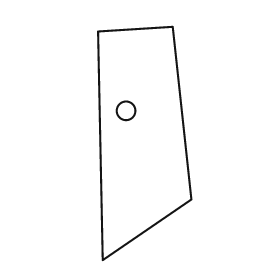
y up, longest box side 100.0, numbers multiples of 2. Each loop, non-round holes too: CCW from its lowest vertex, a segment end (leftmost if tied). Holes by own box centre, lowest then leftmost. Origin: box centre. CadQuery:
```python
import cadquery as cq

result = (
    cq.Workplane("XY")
    .moveTo(-18.0, -50.0)
    .lineTo(20.0, -24.0)
    .lineTo(12.0, 50.0)
    .lineTo(-20.0, 48.0)
    .close()
    .moveTo(-8.0, 14.0)
    .circle(4.0)
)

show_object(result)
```